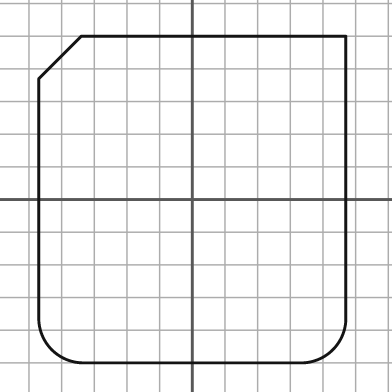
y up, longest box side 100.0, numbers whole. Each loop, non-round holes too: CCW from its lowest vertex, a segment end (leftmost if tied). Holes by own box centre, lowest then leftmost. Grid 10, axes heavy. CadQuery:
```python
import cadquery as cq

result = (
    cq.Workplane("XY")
    .moveTo(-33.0, -50.0)
    .lineTo(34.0, -50.0)
    .threePointArc((43.0, -46.0), (47.0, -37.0))
    .lineTo(47.0, 50.0)
    .lineTo(-34.0, 50.0)
    .lineTo(-47.0, 37.0)
    .lineTo(-47.0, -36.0)
    .threePointArc((-43.0, -46.0), (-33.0, -50.0))
    .close()
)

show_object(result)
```